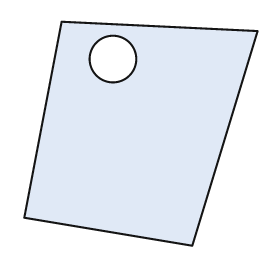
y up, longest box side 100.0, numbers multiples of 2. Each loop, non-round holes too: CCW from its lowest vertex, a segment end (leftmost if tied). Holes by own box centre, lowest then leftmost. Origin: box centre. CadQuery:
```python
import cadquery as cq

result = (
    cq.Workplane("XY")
    .moveTo(22.0, -48.0)
    .lineTo(50.0, 44.0)
    .lineTo(-34.0, 48.0)
    .lineTo(-50.0, -36.0)
    .close()
    .moveTo(-12.0, 32.0)
    .circle(10.0)
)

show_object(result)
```